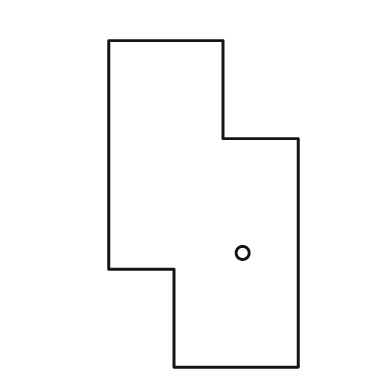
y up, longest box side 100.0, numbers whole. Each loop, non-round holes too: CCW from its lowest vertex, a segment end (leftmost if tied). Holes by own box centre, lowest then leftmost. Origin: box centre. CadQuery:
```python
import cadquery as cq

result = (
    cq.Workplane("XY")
    .moveTo(-9.0, -50.0)
    .lineTo(29.0, -50.0)
    .lineTo(29.0, 20.0)
    .lineTo(6.0, 20.0)
    .lineTo(6.0, 50.0)
    .lineTo(-29.0, 50.0)
    .lineTo(-29.0, -20.0)
    .lineTo(-9.0, -20.0)
    .close()
    .moveTo(12.0, -15.0)
    .circle(2.0)
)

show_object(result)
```